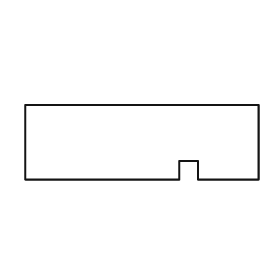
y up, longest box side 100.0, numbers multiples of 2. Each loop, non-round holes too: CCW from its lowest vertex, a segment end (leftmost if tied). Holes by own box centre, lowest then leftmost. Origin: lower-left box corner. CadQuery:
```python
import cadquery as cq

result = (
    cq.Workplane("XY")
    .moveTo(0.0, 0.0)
    .lineTo(66.0, 0.0)
    .lineTo(66.0, 8.0)
    .lineTo(74.0, 8.0)
    .lineTo(74.0, 0.0)
    .lineTo(100.0, 0.0)
    .lineTo(100.0, 32.0)
    .lineTo(0.0, 32.0)
    .close()
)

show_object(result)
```